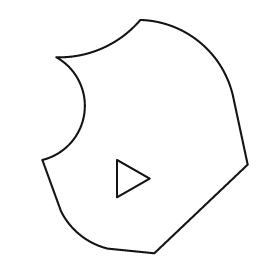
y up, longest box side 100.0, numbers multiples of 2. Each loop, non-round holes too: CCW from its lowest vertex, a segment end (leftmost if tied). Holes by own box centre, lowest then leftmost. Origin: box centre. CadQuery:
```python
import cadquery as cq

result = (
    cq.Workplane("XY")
    .moveTo(4.0, -50.0)
    .lineTo(44.0, -12.0)
    .lineTo(38.0, 16.0)
    .threePointArc((24.0, 40.0), (-2.0, 50.0))
    .threePointArc((-18.0, 38.0), (-38.0, 34.0))
    .threePointArc((-26.0, 10.0), (-44.0, -10.0))
    .lineTo(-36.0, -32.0)
    .threePointArc((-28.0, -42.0), (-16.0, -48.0))
    .close()
    .moveTo(-12.0, -26.0)
    .lineTo(2.0, -18.0)
    .lineTo(-12.0, -10.0)
    .close()
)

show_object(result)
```